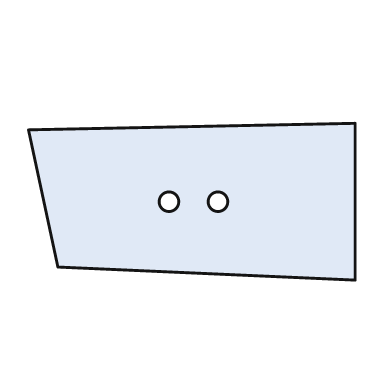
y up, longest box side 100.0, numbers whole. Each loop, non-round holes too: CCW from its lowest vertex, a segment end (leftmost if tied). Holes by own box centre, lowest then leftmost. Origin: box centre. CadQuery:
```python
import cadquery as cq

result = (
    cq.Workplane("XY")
    .moveTo(50.0, -24.0)
    .lineTo(50.0, 24.0)
    .lineTo(-50.0, 22.0)
    .lineTo(-41.0, -20.0)
    .close()
    .moveTo(-7.0, 0.0)
    .circle(3.0)
    .moveTo(8.0, 0.0)
    .circle(3.0)
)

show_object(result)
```